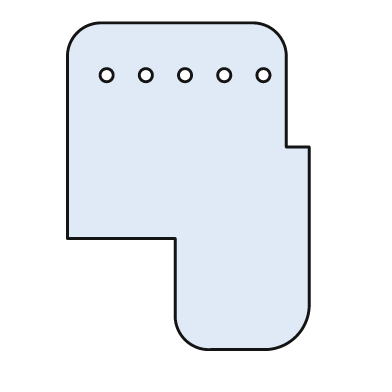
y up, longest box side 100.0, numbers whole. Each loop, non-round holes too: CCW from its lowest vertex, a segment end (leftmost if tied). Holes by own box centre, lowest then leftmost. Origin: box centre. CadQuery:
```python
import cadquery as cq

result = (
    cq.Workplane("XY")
    .moveTo(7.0, -50.0)
    .lineTo(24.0, -50.0)
    .threePointArc((33.0, -46.0), (37.0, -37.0))
    .lineTo(37.0, 12.0)
    .lineTo(30.0, 12.0)
    .lineTo(30.0, 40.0)
    .threePointArc((27.0, 47.0), (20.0, 50.0))
    .lineTo(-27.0, 50.0)
    .threePointArc((-34.0, 47.0), (-37.0, 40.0))
    .lineTo(-37.0, -16.0)
    .lineTo(-4.0, -16.0)
    .lineTo(-4.0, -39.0)
    .threePointArc((-1.0, -47.0), (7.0, -50.0))
    .close()
    .moveTo(-25.0, 34.0)
    .circle(2.0)
    .moveTo(-13.0, 34.0)
    .circle(2.0)
    .moveTo(-1.0, 34.0)
    .circle(2.0)
    .moveTo(11.0, 34.0)
    .circle(2.0)
    .moveTo(23.0, 34.0)
    .circle(2.0)
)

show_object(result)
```